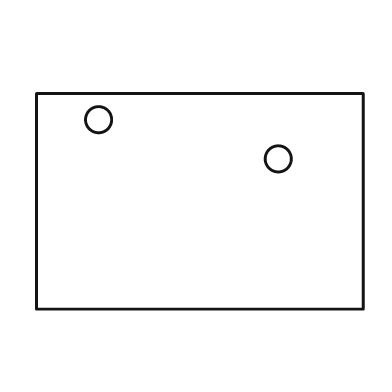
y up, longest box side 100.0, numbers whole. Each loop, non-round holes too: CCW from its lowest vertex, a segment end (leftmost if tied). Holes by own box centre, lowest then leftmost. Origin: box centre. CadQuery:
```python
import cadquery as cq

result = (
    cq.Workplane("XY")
    .moveTo(-50.0, -33.0)
    .lineTo(50.0, -33.0)
    .lineTo(50.0, 33.0)
    .lineTo(-50.0, 33.0)
    .close()
    .moveTo(24.0, 13.0)
    .circle(4.0)
    .moveTo(-31.0, 25.0)
    .circle(4.0)
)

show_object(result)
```